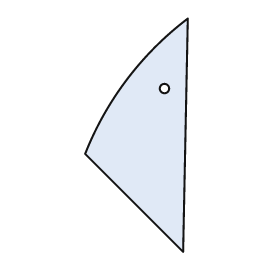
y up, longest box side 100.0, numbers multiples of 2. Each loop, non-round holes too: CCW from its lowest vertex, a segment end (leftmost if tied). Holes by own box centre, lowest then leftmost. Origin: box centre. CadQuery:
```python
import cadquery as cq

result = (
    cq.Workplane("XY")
    .moveTo(20.0, -50.0)
    .lineTo(22.0, 50.0)
    .threePointArc((-4.0, 24.0), (-22.0, -8.0))
    .close()
    .moveTo(12.0, 20.0)
    .circle(2.0)
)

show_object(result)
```